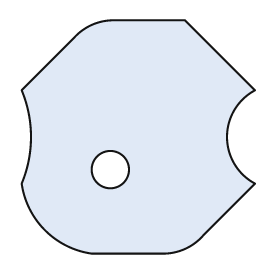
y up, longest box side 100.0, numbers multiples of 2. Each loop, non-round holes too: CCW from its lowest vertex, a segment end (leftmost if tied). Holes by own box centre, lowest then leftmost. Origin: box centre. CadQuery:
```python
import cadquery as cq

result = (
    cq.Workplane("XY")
    .moveTo(-20.0, -50.0)
    .lineTo(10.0, -50.0)
    .threePointArc((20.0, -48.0), (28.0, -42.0))
    .lineTo(50.0, -20.0)
    .threePointArc((38.0, 0.0), (50.0, 20.0))
    .lineTo(20.0, 50.0)
    .lineTo(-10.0, 50.0)
    .threePointArc((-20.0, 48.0), (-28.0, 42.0))
    .lineTo(-50.0, 20.0)
    .threePointArc((-46.0, 0.0), (-50.0, -20.0))
    .threePointArc((-40.0, -40.0), (-20.0, -50.0))
    .close()
    .moveTo(-12.0, -14.0)
    .circle(8.0)
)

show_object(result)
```